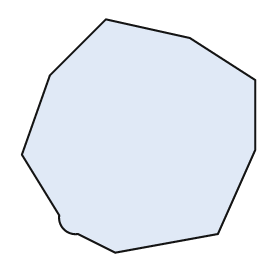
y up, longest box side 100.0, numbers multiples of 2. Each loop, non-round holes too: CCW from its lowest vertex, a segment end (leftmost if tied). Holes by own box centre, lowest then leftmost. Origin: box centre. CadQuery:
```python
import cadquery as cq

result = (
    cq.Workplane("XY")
    .moveTo(-10.0, -50.0)
    .lineTo(34.0, -42.0)
    .lineTo(50.0, -6.0)
    .lineTo(50.0, 24.0)
    .lineTo(22.0, 42.0)
    .lineTo(-14.0, 50.0)
    .lineTo(-38.0, 26.0)
    .lineTo(-50.0, -8.0)
    .lineTo(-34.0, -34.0)
    .threePointArc((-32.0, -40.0), (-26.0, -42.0))
    .close()
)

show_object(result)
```